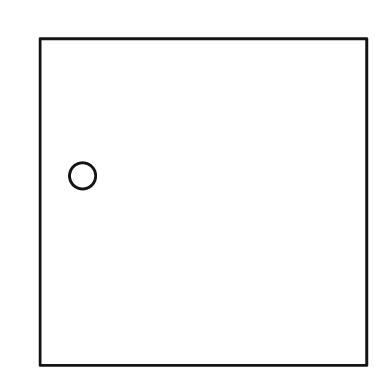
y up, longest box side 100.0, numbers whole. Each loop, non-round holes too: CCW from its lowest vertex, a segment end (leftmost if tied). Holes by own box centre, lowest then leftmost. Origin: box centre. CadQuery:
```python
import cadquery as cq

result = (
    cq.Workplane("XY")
    .moveTo(-50.0, -50.0)
    .lineTo(50.0, -50.0)
    .lineTo(50.0, 50.0)
    .lineTo(-50.0, 50.0)
    .close()
    .moveTo(-37.0, 8.0)
    .circle(4.0)
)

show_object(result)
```